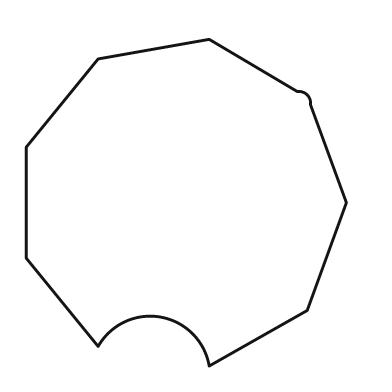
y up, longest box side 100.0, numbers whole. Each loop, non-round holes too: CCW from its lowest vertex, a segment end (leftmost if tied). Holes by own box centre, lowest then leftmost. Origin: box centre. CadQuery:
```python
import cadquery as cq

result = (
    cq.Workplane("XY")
    .moveTo(7.0, -50.0)
    .lineTo(37.0, -33.0)
    .lineTo(49.0, 0.0)
    .lineTo(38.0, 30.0)
    .threePointArc((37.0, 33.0), (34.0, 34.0))
    .lineTo(7.0, 50.0)
    .lineTo(-27.0, 44.0)
    .lineTo(-49.0, 17.0)
    .lineTo(-49.0, -17.0)
    .lineTo(-27.0, -44.0)
    .threePointArc((-8.0, -35.0), (7.0, -50.0))
    .close()
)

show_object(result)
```